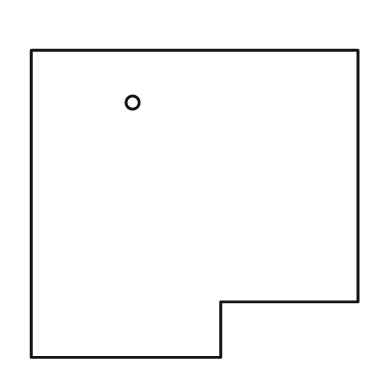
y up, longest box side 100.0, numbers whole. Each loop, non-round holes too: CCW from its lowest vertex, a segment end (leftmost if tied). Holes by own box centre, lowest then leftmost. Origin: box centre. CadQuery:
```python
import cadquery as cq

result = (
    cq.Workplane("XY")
    .moveTo(-50.0, -47.0)
    .lineTo(8.0, -47.0)
    .lineTo(8.0, -30.0)
    .lineTo(50.0, -30.0)
    .lineTo(50.0, 47.0)
    .lineTo(-50.0, 47.0)
    .close()
    .moveTo(-19.0, 31.0)
    .circle(2.0)
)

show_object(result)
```